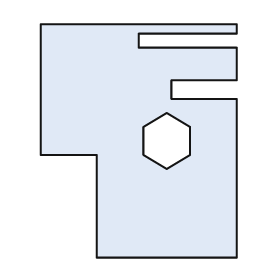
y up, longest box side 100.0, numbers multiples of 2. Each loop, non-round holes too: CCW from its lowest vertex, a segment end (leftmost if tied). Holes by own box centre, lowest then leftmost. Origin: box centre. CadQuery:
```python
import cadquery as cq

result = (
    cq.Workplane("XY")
    .moveTo(-18.0, -50.0)
    .lineTo(42.0, -50.0)
    .lineTo(42.0, 18.0)
    .lineTo(14.0, 18.0)
    .lineTo(14.0, 26.0)
    .lineTo(42.0, 26.0)
    .lineTo(42.0, 40.0)
    .lineTo(0.0, 40.0)
    .lineTo(0.0, 46.0)
    .lineTo(42.0, 46.0)
    .lineTo(42.0, 50.0)
    .lineTo(-42.0, 50.0)
    .lineTo(-42.0, -6.0)
    .lineTo(-18.0, -6.0)
    .close()
    .moveTo(12.0, -12.0)
    .lineTo(22.0, -6.0)
    .lineTo(22.0, 6.0)
    .lineTo(12.0, 12.0)
    .lineTo(2.0, 6.0)
    .lineTo(2.0, -6.0)
    .close()
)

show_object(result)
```